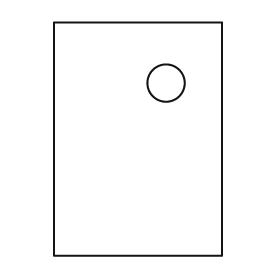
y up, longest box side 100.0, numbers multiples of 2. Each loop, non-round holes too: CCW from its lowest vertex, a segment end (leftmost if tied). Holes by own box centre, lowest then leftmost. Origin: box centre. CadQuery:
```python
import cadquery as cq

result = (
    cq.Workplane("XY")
    .moveTo(-36.0, -50.0)
    .lineTo(36.0, -50.0)
    .lineTo(36.0, 50.0)
    .lineTo(-36.0, 50.0)
    .close()
    .moveTo(12.0, 24.0)
    .circle(8.0)
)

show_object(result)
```